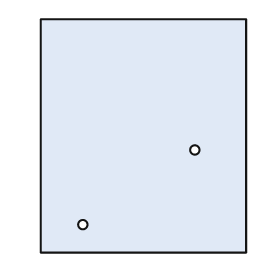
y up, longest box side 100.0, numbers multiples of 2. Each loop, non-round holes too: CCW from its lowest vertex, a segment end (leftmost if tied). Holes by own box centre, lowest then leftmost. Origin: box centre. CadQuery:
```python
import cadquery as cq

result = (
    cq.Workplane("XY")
    .moveTo(-44.0, -50.0)
    .lineTo(44.0, -50.0)
    .lineTo(44.0, 50.0)
    .lineTo(-44.0, 50.0)
    .close()
    .moveTo(-26.0, -38.0)
    .circle(2.0)
    .moveTo(22.0, -6.0)
    .circle(2.0)
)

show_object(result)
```